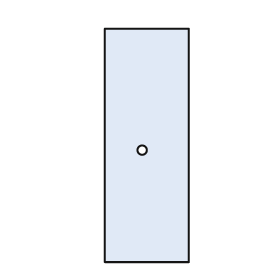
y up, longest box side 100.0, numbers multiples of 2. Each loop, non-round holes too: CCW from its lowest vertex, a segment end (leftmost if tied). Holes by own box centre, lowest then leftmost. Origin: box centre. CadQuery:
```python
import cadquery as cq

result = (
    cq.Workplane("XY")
    .moveTo(-18.0, -50.0)
    .lineTo(18.0, -50.0)
    .lineTo(18.0, 50.0)
    .lineTo(-18.0, 50.0)
    .close()
    .moveTo(-2.0, -2.0)
    .circle(2.0)
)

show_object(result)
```